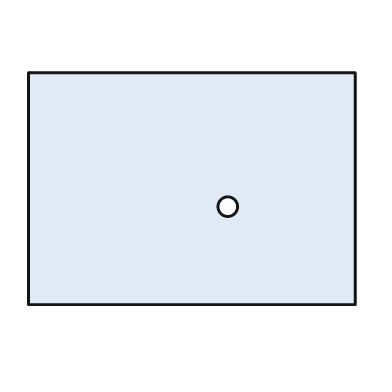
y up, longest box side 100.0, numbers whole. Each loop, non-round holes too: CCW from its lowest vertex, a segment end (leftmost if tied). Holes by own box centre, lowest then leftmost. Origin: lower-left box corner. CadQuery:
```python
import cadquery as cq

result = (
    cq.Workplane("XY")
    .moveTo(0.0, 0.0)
    .lineTo(100.0, 0.0)
    .lineTo(100.0, 71.0)
    .lineTo(0.0, 71.0)
    .close()
    .moveTo(61.0, 30.0)
    .circle(3.0)
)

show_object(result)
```